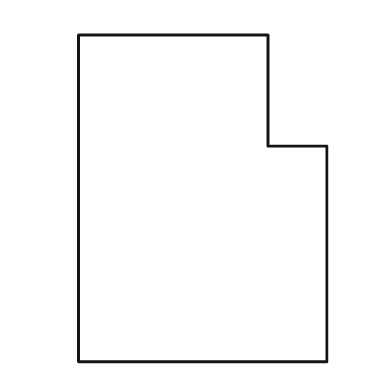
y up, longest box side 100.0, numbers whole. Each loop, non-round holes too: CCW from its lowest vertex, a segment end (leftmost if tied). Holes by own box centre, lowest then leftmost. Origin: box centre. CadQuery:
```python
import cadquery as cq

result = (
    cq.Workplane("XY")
    .moveTo(-38.0, -50.0)
    .lineTo(38.0, -50.0)
    .lineTo(38.0, 16.0)
    .lineTo(20.0, 16.0)
    .lineTo(20.0, 50.0)
    .lineTo(-38.0, 50.0)
    .close()
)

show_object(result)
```